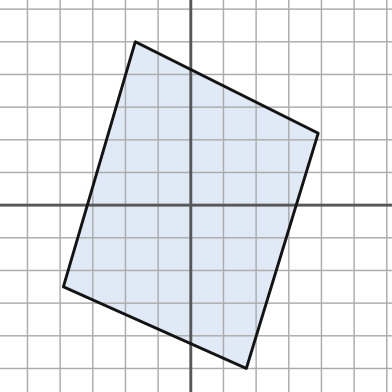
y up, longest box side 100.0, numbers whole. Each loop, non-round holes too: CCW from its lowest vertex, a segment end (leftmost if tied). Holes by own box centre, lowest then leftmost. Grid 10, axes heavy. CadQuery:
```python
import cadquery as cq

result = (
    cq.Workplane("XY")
    .moveTo(17.0, -50.0)
    .lineTo(39.0, 22.0)
    .lineTo(-17.0, 50.0)
    .lineTo(-39.0, -25.0)
    .close()
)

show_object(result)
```